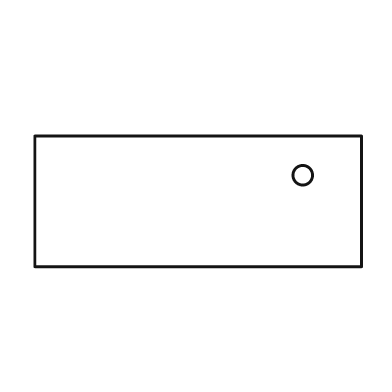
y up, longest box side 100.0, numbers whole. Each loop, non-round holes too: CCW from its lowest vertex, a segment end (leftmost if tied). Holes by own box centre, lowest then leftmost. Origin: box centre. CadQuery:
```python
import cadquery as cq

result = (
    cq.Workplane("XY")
    .moveTo(-50.0, -20.0)
    .lineTo(50.0, -20.0)
    .lineTo(50.0, 20.0)
    .lineTo(-50.0, 20.0)
    .close()
    .moveTo(32.0, 8.0)
    .circle(3.0)
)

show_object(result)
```